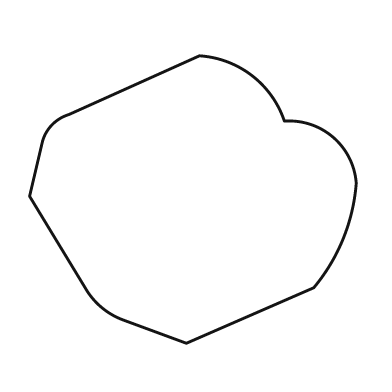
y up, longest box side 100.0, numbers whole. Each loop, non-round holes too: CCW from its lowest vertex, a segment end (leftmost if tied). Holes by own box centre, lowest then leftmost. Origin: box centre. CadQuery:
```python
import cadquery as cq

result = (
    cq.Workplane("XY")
    .moveTo(-2.0, -44.0)
    .lineTo(37.0, -27.0)
    .threePointArc((46.0, -12.0), (50.0, 5.0))
    .threePointArc((43.0, 19.0), (28.0, 24.0))
    .threePointArc((18.0, 38.0), (2.0, 44.0))
    .lineTo(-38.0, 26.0)
    .threePointArc((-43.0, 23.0), (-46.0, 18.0))
    .lineTo(-50.0, 1.0)
    .lineTo(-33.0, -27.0)
    .threePointArc((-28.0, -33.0), (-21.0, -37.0))
    .close()
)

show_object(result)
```